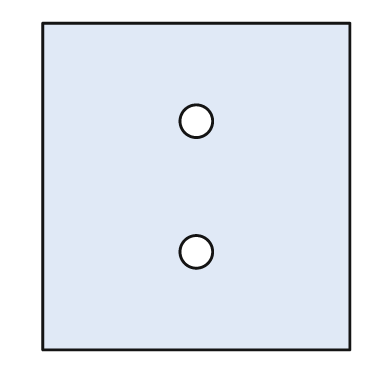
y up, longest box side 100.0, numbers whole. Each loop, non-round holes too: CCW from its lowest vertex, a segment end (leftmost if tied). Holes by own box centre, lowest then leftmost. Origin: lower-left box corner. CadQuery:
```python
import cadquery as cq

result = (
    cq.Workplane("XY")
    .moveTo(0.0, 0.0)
    .lineTo(94.0, 0.0)
    .lineTo(94.0, 100.0)
    .lineTo(0.0, 100.0)
    .close()
    .moveTo(47.0, 30.0)
    .circle(5.0)
    .moveTo(47.0, 70.0)
    .circle(5.0)
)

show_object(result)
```